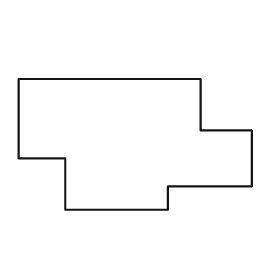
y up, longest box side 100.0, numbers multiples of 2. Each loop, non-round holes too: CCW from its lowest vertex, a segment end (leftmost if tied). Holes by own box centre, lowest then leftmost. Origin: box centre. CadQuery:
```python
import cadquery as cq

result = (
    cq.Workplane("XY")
    .moveTo(-30.0, -28.0)
    .lineTo(14.0, -28.0)
    .lineTo(14.0, -18.0)
    .lineTo(50.0, -18.0)
    .lineTo(50.0, 6.0)
    .lineTo(28.0, 6.0)
    .lineTo(28.0, 28.0)
    .lineTo(-50.0, 28.0)
    .lineTo(-50.0, -6.0)
    .lineTo(-30.0, -6.0)
    .close()
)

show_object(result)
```